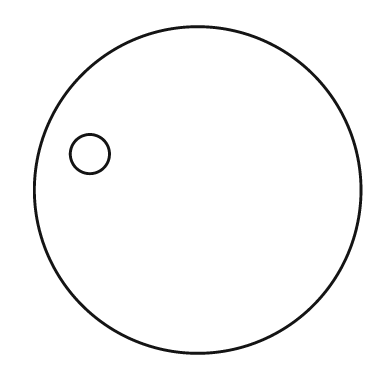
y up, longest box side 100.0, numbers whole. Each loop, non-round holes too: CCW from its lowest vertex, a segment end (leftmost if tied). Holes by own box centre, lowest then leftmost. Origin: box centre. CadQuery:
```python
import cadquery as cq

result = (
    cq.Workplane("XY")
    .moveTo(0.0, 0.0)
    .circle(50.0)
    .moveTo(-33.0, 11.0)
    .circle(6.0)
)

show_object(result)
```